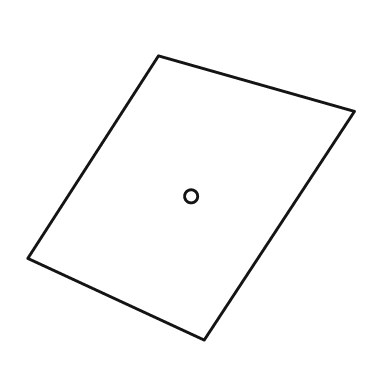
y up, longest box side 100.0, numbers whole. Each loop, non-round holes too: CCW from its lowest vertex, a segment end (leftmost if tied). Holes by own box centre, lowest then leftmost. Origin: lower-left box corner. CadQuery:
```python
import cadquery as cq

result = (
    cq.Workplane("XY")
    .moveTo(54.0, 0.0)
    .lineTo(100.0, 70.0)
    .lineTo(40.0, 87.0)
    .lineTo(0.0, 25.0)
    .close()
    .moveTo(50.0, 44.0)
    .circle(2.0)
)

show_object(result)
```